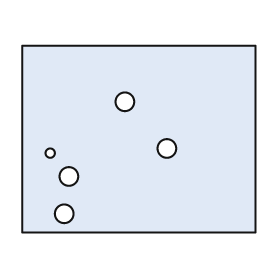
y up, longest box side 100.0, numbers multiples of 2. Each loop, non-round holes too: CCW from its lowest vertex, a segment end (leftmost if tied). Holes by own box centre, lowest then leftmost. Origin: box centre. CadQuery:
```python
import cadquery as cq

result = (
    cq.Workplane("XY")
    .moveTo(-50.0, -40.0)
    .lineTo(50.0, -40.0)
    .lineTo(50.0, 40.0)
    .lineTo(-50.0, 40.0)
    .close()
    .moveTo(-32.0, -32.0)
    .circle(4.0)
    .moveTo(-30.0, -16.0)
    .circle(4.0)
    .moveTo(-38.0, -6.0)
    .circle(2.0)
    .moveTo(12.0, -4.0)
    .circle(4.0)
    .moveTo(-6.0, 16.0)
    .circle(4.0)
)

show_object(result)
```